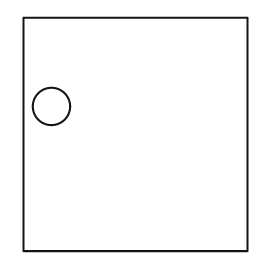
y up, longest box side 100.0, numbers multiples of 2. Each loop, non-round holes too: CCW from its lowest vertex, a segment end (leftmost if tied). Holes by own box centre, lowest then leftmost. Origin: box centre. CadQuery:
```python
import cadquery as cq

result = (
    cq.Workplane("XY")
    .moveTo(-48.0, -50.0)
    .lineTo(48.0, -50.0)
    .lineTo(48.0, 50.0)
    .lineTo(-48.0, 50.0)
    .close()
    .moveTo(-36.0, 12.0)
    .circle(8.0)
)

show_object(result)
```